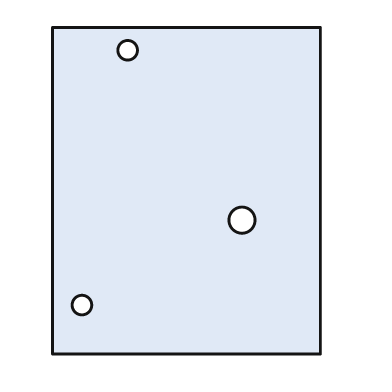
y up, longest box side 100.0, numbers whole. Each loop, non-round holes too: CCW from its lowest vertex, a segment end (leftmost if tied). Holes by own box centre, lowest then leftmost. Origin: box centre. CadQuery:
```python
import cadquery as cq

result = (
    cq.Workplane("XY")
    .moveTo(-41.0, -50.0)
    .lineTo(41.0, -50.0)
    .lineTo(41.0, 50.0)
    .lineTo(-41.0, 50.0)
    .close()
    .moveTo(-32.0, -35.0)
    .circle(3.0)
    .moveTo(17.0, -9.0)
    .circle(4.0)
    .moveTo(-18.0, 43.0)
    .circle(3.0)
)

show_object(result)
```